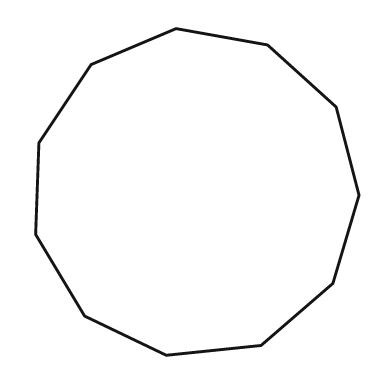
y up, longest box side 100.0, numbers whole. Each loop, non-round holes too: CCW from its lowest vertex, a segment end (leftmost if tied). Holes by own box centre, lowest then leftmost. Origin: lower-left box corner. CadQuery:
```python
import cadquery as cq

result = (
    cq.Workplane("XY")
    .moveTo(40.0, 0.0)
    .lineTo(69.0, 3.0)
    .lineTo(91.0, 22.0)
    .lineTo(99.0, 49.0)
    .lineTo(92.0, 76.0)
    .lineTo(71.0, 95.0)
    .lineTo(43.0, 100.0)
    .lineTo(17.0, 89.0)
    .lineTo(1.0, 65.0)
    .lineTo(0.0, 37.0)
    .lineTo(15.0, 12.0)
    .close()
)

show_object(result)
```